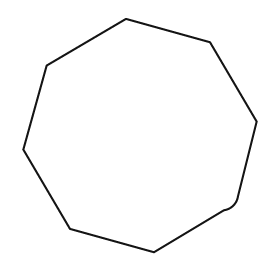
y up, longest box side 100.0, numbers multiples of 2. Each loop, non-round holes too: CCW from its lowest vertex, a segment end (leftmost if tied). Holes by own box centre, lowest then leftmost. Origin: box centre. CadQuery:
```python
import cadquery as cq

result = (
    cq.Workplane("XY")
    .moveTo(6.0, -50.0)
    .lineTo(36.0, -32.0)
    .threePointArc((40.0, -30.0), (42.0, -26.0))
    .lineTo(50.0, 6.0)
    .lineTo(30.0, 40.0)
    .lineTo(-6.0, 50.0)
    .lineTo(-40.0, 30.0)
    .lineTo(-50.0, -6.0)
    .lineTo(-30.0, -40.0)
    .close()
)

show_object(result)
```